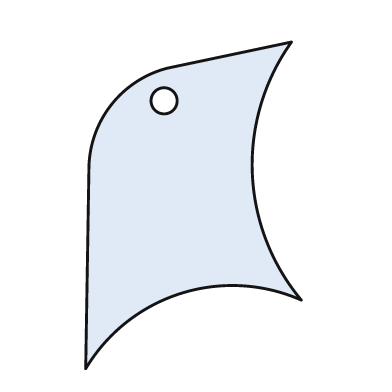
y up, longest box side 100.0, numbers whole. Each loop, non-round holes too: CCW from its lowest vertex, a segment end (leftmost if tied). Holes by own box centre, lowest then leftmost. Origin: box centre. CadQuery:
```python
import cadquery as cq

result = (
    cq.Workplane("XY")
    .moveTo(-33.0, -50.0)
    .threePointArc((-4.0, -27.0), (33.0, -29.0))
    .threePointArc((18.0, 10.0), (30.0, 50.0))
    .lineTo(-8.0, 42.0)
    .threePointArc((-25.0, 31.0), (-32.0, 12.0))
    .close()
    .moveTo(-9.0, 32.0)
    .circle(4.0)
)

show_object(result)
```